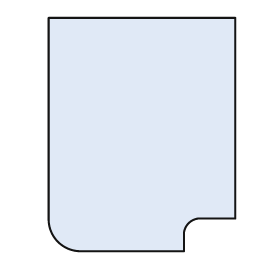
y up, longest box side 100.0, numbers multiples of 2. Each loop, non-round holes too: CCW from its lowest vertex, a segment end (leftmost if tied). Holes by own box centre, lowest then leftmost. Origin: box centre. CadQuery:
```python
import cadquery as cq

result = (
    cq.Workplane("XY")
    .moveTo(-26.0, -50.0)
    .lineTo(18.0, -50.0)
    .lineTo(18.0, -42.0)
    .threePointArc((20.0, -38.0), (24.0, -36.0))
    .lineTo(40.0, -36.0)
    .lineTo(40.0, 50.0)
    .lineTo(-40.0, 50.0)
    .lineTo(-40.0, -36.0)
    .threePointArc((-36.0, -46.0), (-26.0, -50.0))
    .close()
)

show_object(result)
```